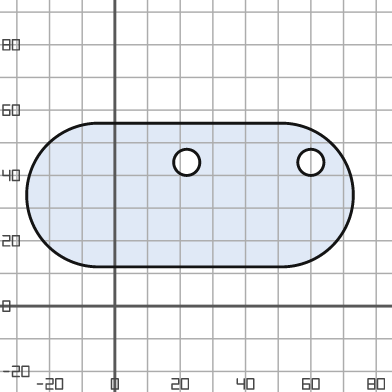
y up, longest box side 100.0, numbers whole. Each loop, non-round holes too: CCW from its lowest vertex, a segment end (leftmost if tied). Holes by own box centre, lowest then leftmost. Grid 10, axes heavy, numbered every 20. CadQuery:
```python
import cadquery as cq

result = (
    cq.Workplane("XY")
    .moveTo(-5.0, 12.0)
    .lineTo(51.0, 12.0)
    .threePointArc((73.0, 34.0), (51.0, 56.0))
    .lineTo(-5.0, 56.0)
    .threePointArc((-27.0, 34.0), (-5.0, 12.0))
    .close()
    .moveTo(22.0, 44.0)
    .circle(4.0)
    .moveTo(60.0, 44.0)
    .circle(4.0)
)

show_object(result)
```